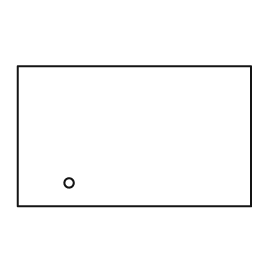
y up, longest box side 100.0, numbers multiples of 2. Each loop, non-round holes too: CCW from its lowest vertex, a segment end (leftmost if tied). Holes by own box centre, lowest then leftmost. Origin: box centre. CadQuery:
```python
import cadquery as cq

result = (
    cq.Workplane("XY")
    .moveTo(-50.0, -30.0)
    .lineTo(50.0, -30.0)
    .lineTo(50.0, 30.0)
    .lineTo(-50.0, 30.0)
    .close()
    .moveTo(-28.0, -20.0)
    .circle(2.0)
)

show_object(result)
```